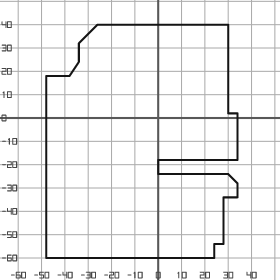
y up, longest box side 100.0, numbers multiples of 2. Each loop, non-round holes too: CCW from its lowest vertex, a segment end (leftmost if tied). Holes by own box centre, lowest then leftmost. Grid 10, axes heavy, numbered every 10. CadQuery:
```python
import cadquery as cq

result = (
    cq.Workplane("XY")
    .moveTo(-48.0, -60.0)
    .lineTo(24.0, -60.0)
    .lineTo(24.0, -54.0)
    .lineTo(28.0, -54.0)
    .lineTo(28.0, -34.0)
    .lineTo(34.0, -34.0)
    .lineTo(34.0, -28.0)
    .lineTo(30.0, -24.0)
    .lineTo(0.0, -24.0)
    .lineTo(0.0, -18.0)
    .lineTo(34.0, -18.0)
    .lineTo(34.0, 2.0)
    .lineTo(30.0, 2.0)
    .lineTo(30.0, 40.0)
    .lineTo(-26.0, 40.0)
    .lineTo(-34.0, 32.0)
    .lineTo(-34.0, 24.0)
    .lineTo(-38.0, 18.0)
    .lineTo(-48.0, 18.0)
    .close()
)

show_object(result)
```